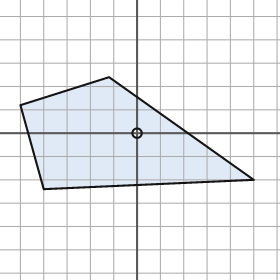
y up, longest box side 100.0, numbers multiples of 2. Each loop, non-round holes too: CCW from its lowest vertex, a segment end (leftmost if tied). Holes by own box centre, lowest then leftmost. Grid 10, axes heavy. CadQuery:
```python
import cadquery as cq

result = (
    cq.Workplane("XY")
    .moveTo(-40.0, -24.0)
    .lineTo(50.0, -20.0)
    .lineTo(-12.0, 24.0)
    .lineTo(-50.0, 12.0)
    .close()
    .moveTo(0.0, 0.0)
    .circle(2.0)
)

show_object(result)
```